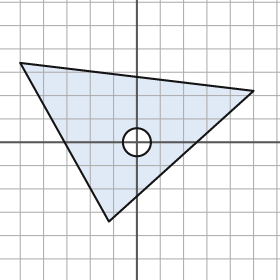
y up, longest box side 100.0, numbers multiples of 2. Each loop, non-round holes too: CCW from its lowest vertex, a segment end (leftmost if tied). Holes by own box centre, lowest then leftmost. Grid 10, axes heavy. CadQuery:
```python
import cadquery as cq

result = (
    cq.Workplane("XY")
    .moveTo(-12.0, -34.0)
    .lineTo(50.0, 22.0)
    .lineTo(-50.0, 34.0)
    .close()
    .moveTo(0.0, 0.0)
    .circle(6.0)
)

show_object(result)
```